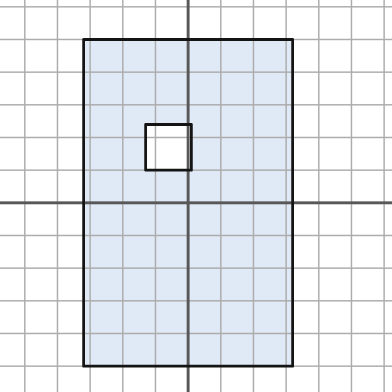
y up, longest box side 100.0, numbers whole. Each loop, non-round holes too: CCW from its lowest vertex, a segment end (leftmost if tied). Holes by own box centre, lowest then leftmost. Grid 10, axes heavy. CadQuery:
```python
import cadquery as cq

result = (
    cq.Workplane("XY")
    .moveTo(-32.0, -50.0)
    .lineTo(32.0, -50.0)
    .lineTo(32.0, 50.0)
    .lineTo(-32.0, 50.0)
    .close()
    .moveTo(-13.0, 10.0)
    .lineTo(1.0, 10.0)
    .lineTo(1.0, 24.0)
    .lineTo(-13.0, 24.0)
    .close()
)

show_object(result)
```